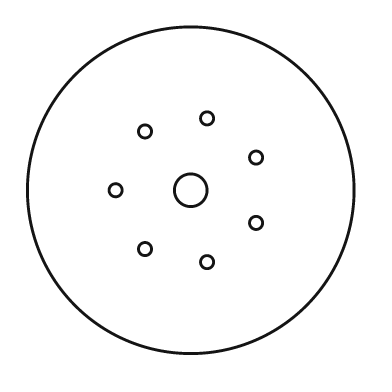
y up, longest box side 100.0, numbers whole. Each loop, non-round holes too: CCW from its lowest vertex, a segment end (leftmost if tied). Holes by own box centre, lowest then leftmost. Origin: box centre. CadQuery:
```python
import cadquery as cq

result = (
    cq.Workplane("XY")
    .moveTo(0.0, 0.0)
    .circle(50.0)
    .moveTo(5.0, -22.0)
    .circle(2.0)
    .moveTo(-14.0, -18.0)
    .circle(2.0)
    .moveTo(20.0, -10.0)
    .circle(2.0)
    .moveTo(-23.0, 0.0)
    .circle(2.0)
    .moveTo(0.0, 0.0)
    .circle(5.0)
    .moveTo(20.0, 10.0)
    .circle(2.0)
    .moveTo(-14.0, 18.0)
    .circle(2.0)
    .moveTo(5.0, 22.0)
    .circle(2.0)
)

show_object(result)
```